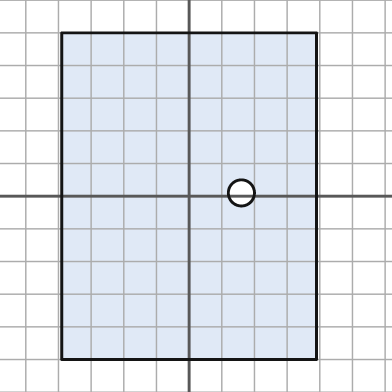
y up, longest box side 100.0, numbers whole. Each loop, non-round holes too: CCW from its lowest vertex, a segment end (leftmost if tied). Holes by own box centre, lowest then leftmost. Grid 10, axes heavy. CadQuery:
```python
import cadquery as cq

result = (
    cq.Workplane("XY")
    .moveTo(-39.0, -50.0)
    .lineTo(39.0, -50.0)
    .lineTo(39.0, 50.0)
    .lineTo(-39.0, 50.0)
    .close()
    .moveTo(16.0, 1.0)
    .circle(4.0)
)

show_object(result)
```